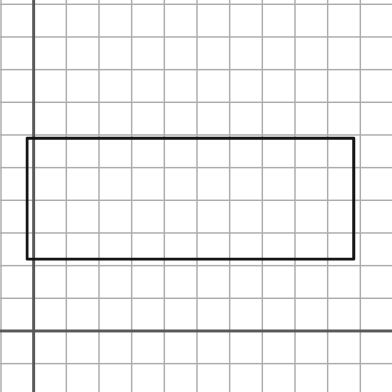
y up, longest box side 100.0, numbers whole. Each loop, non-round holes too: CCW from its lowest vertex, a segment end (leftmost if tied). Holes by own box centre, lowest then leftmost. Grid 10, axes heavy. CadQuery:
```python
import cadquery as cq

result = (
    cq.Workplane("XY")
    .moveTo(-2.0, 22.0)
    .lineTo(98.0, 22.0)
    .lineTo(98.0, 59.0)
    .lineTo(-2.0, 59.0)
    .close()
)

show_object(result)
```